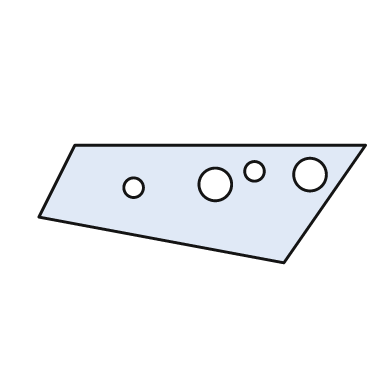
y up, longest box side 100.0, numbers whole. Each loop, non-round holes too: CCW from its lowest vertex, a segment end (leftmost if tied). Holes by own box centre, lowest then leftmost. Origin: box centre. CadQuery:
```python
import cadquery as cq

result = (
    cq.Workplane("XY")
    .moveTo(25.0, -18.0)
    .lineTo(50.0, 18.0)
    .lineTo(-39.0, 18.0)
    .lineTo(-50.0, -4.0)
    .close()
    .moveTo(-21.0, 5.0)
    .circle(3.0)
    .moveTo(4.0, 6.0)
    .circle(5.0)
    .moveTo(33.0, 9.0)
    .circle(5.0)
    .moveTo(16.0, 10.0)
    .circle(3.0)
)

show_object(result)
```